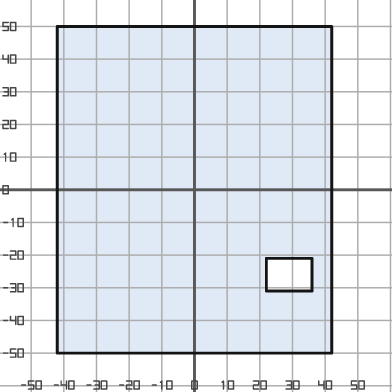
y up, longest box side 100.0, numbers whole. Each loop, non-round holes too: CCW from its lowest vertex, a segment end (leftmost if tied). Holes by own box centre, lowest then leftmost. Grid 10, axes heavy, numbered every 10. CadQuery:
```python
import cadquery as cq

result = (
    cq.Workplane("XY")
    .moveTo(-42.0, -50.0)
    .lineTo(42.0, -50.0)
    .lineTo(42.0, 50.0)
    .lineTo(-42.0, 50.0)
    .close()
    .moveTo(22.0, -31.0)
    .lineTo(36.0, -31.0)
    .lineTo(36.0, -21.0)
    .lineTo(22.0, -21.0)
    .close()
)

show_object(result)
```